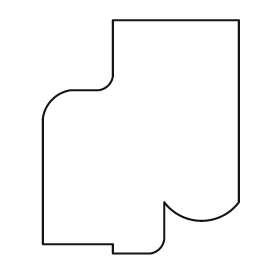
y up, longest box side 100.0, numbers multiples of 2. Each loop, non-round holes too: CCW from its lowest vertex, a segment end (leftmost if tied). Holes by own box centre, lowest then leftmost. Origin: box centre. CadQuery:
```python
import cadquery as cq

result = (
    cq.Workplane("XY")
    .moveTo(-12.0, -50.0)
    .lineTo(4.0, -50.0)
    .threePointArc((8.0, -48.0), (10.0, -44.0))
    .lineTo(10.0, -28.0)
    .threePointArc((26.0, -36.0), (42.0, -28.0))
    .lineTo(42.0, 50.0)
    .lineTo(-12.0, 50.0)
    .lineTo(-12.0, 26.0)
    .threePointArc((-14.0, 22.0), (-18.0, 20.0))
    .lineTo(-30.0, 20.0)
    .threePointArc((-38.0, 16.0), (-42.0, 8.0))
    .lineTo(-42.0, -46.0)
    .lineTo(-12.0, -46.0)
    .close()
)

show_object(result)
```